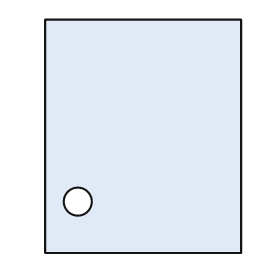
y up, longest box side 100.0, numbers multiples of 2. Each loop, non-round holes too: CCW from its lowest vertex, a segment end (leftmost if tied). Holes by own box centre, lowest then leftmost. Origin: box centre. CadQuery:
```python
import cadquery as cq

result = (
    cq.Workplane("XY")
    .moveTo(-42.0, -50.0)
    .lineTo(42.0, -50.0)
    .lineTo(42.0, 50.0)
    .lineTo(-42.0, 50.0)
    .close()
    .moveTo(-28.0, -28.0)
    .circle(6.0)
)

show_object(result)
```